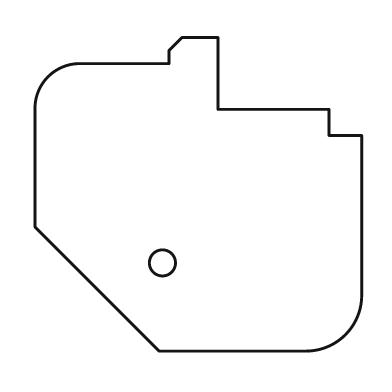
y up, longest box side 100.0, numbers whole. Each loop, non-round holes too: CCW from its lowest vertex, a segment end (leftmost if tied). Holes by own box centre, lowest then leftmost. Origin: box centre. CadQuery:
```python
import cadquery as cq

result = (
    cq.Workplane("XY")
    .moveTo(-12.0, -48.0)
    .lineTo(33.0, -48.0)
    .threePointArc((45.0, -43.0), (50.0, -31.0))
    .lineTo(50.0, 18.0)
    .lineTo(40.0, 18.0)
    .lineTo(40.0, 26.0)
    .lineTo(6.0, 26.0)
    .lineTo(6.0, 48.0)
    .lineTo(-5.0, 48.0)
    .lineTo(-9.0, 44.0)
    .lineTo(-9.0, 40.0)
    .lineTo(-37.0, 40.0)
    .threePointArc((-46.0, 36.0), (-50.0, 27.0))
    .lineTo(-50.0, -10.0)
    .close()
    .moveTo(-11.0, -21.0)
    .circle(4.0)
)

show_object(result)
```